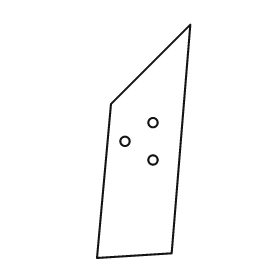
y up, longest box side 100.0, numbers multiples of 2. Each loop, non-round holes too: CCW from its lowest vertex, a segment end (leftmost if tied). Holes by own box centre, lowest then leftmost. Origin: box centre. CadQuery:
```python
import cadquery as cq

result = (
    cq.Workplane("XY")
    .moveTo(-20.0, -50.0)
    .lineTo(12.0, -48.0)
    .lineTo(20.0, 50.0)
    .lineTo(-14.0, 16.0)
    .close()
    .moveTo(4.0, -8.0)
    .circle(2.0)
    .moveTo(-8.0, 0.0)
    .circle(2.0)
    .moveTo(4.0, 8.0)
    .circle(2.0)
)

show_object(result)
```